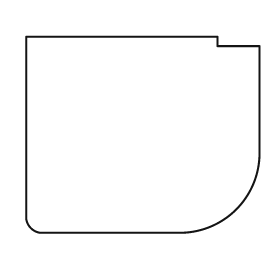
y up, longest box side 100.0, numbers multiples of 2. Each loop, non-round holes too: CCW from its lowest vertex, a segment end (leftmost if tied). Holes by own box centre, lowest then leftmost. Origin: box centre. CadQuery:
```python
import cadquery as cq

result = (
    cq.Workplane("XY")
    .moveTo(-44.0, -42.0)
    .lineTo(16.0, -42.0)
    .threePointArc((40.0, -32.0), (50.0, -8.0))
    .lineTo(50.0, 38.0)
    .lineTo(32.0, 38.0)
    .lineTo(32.0, 42.0)
    .lineTo(-50.0, 42.0)
    .lineTo(-50.0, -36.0)
    .threePointArc((-48.0, -40.0), (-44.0, -42.0))
    .close()
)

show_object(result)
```